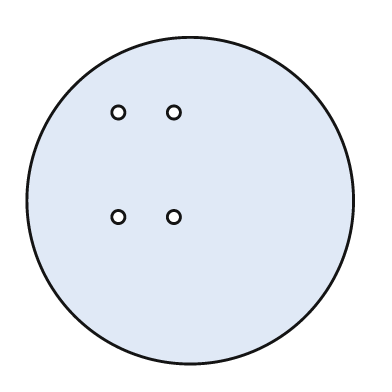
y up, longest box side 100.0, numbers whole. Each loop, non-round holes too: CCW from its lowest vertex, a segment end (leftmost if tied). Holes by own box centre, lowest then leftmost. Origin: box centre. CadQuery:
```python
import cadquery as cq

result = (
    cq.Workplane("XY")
    .moveTo(0.0, 0.0)
    .circle(50.0)
    .moveTo(-22.0, -5.0)
    .circle(2.0)
    .moveTo(-5.0, -5.0)
    .circle(2.0)
    .moveTo(-22.0, 27.0)
    .circle(2.0)
    .moveTo(-5.0, 27.0)
    .circle(2.0)
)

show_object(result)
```